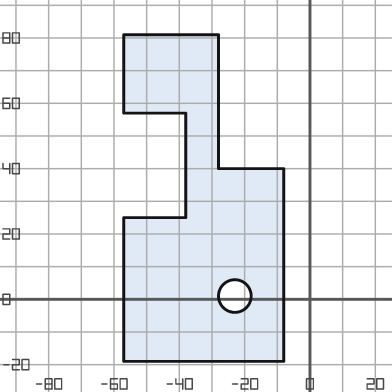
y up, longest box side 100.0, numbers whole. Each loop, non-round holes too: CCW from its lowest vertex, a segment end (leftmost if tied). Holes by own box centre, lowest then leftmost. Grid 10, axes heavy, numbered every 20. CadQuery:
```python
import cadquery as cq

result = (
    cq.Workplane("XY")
    .moveTo(-57.0, -19.0)
    .lineTo(-8.0, -19.0)
    .lineTo(-8.0, 40.0)
    .lineTo(-28.0, 40.0)
    .lineTo(-28.0, 81.0)
    .lineTo(-57.0, 81.0)
    .lineTo(-57.0, 57.0)
    .lineTo(-38.0, 57.0)
    .lineTo(-38.0, 25.0)
    .lineTo(-57.0, 25.0)
    .close()
    .moveTo(-23.0, 1.0)
    .circle(5.0)
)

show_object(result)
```